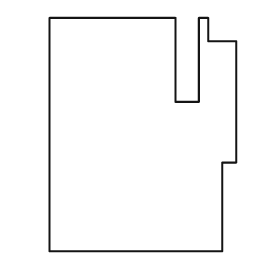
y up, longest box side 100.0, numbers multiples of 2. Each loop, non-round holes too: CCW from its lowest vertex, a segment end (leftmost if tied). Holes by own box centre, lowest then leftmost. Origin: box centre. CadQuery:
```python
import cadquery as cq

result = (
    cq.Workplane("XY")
    .moveTo(-40.0, -50.0)
    .lineTo(34.0, -50.0)
    .lineTo(34.0, -12.0)
    .lineTo(40.0, -12.0)
    .lineTo(40.0, 40.0)
    .lineTo(28.0, 40.0)
    .lineTo(28.0, 50.0)
    .lineTo(24.0, 50.0)
    .lineTo(24.0, 14.0)
    .lineTo(14.0, 14.0)
    .lineTo(14.0, 50.0)
    .lineTo(-40.0, 50.0)
    .close()
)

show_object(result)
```